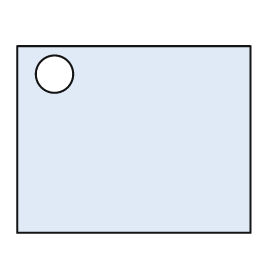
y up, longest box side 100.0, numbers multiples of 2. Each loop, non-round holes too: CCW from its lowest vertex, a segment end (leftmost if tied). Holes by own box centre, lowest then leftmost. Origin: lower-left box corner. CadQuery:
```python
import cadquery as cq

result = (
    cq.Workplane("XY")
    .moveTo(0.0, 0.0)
    .lineTo(100.0, 0.0)
    .lineTo(100.0, 80.0)
    .lineTo(0.0, 80.0)
    .close()
    .moveTo(16.0, 68.0)
    .circle(8.0)
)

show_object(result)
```